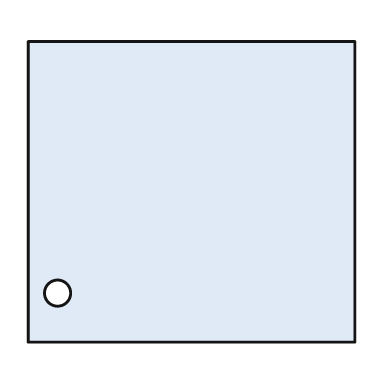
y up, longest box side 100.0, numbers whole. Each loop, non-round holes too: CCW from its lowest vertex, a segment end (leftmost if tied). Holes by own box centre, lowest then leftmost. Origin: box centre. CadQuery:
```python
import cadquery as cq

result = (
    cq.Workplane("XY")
    .moveTo(-50.0, -46.0)
    .lineTo(50.0, -46.0)
    .lineTo(50.0, 46.0)
    .lineTo(-50.0, 46.0)
    .close()
    .moveTo(-41.0, -31.0)
    .circle(4.0)
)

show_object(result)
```